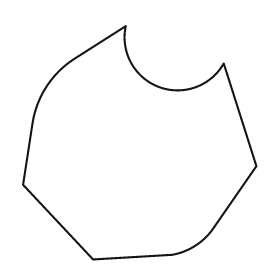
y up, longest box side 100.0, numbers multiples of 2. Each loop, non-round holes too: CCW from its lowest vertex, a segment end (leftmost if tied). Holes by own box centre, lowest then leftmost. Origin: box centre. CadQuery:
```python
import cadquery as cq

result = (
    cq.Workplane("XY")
    .moveTo(-20.0, -50.0)
    .lineTo(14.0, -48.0)
    .threePointArc((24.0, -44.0), (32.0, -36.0))
    .lineTo(50.0, -10.0)
    .lineTo(36.0, 34.0)
    .threePointArc((8.0, 24.0), (-6.0, 50.0))
    .lineTo(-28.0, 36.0)
    .threePointArc((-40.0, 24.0), (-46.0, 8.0))
    .lineTo(-50.0, -18.0)
    .close()
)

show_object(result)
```